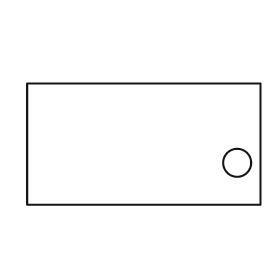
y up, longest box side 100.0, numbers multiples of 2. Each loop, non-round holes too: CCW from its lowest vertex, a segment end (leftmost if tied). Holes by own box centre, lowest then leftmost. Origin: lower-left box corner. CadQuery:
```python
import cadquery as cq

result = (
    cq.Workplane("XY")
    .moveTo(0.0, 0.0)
    .lineTo(100.0, 0.0)
    .lineTo(100.0, 52.0)
    .lineTo(0.0, 52.0)
    .close()
    .moveTo(90.0, 18.0)
    .circle(6.0)
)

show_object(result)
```